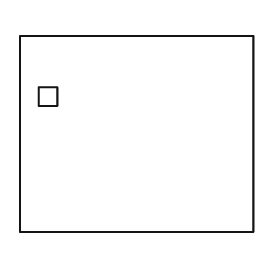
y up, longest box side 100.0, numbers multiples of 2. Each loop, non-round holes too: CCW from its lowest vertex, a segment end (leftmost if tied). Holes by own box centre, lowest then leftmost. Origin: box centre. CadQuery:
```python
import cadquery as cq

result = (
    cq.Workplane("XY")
    .moveTo(-50.0, -42.0)
    .lineTo(50.0, -42.0)
    .lineTo(50.0, 42.0)
    .lineTo(-50.0, 42.0)
    .close()
    .moveTo(-42.0, 12.0)
    .lineTo(-34.0, 12.0)
    .lineTo(-34.0, 20.0)
    .lineTo(-42.0, 20.0)
    .close()
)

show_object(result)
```